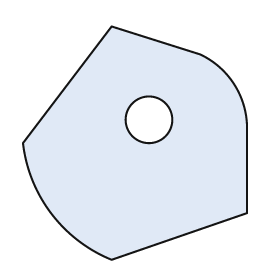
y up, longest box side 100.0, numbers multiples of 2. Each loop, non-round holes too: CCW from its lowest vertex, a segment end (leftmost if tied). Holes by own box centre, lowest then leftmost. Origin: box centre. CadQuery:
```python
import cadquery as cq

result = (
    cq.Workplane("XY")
    .moveTo(-10.0, -50.0)
    .lineTo(48.0, -30.0)
    .lineTo(48.0, 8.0)
    .threePointArc((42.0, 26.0), (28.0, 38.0))
    .lineTo(-10.0, 50.0)
    .lineTo(-48.0, 0.0)
    .threePointArc((-36.0, -30.0), (-10.0, -50.0))
    .close()
    .moveTo(6.0, 10.0)
    .circle(10.0)
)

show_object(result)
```